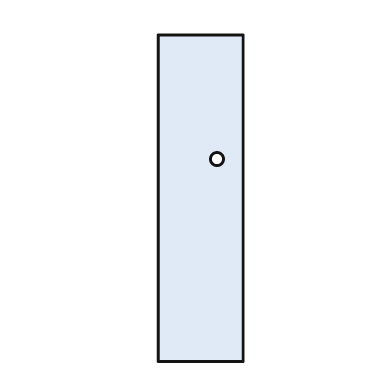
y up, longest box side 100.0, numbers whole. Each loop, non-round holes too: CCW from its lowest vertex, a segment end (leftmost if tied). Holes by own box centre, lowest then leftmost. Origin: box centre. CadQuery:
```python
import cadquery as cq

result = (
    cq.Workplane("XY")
    .moveTo(-13.0, -50.0)
    .lineTo(13.0, -50.0)
    .lineTo(13.0, 50.0)
    .lineTo(-13.0, 50.0)
    .close()
    .moveTo(5.0, 12.0)
    .circle(2.0)
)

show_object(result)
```